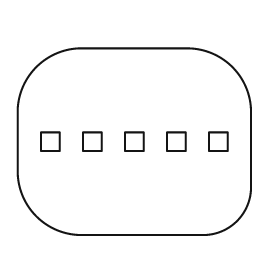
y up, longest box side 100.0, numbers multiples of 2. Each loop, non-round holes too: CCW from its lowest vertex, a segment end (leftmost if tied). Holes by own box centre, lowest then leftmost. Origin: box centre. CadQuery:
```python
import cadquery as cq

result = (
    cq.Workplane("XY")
    .moveTo(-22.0, -40.0)
    .lineTo(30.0, -40.0)
    .threePointArc((44.0, -34.0), (50.0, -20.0))
    .lineTo(50.0, 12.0)
    .threePointArc((42.0, 32.0), (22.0, 40.0))
    .lineTo(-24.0, 40.0)
    .threePointArc((-42.0, 32.0), (-50.0, 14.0))
    .lineTo(-50.0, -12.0)
    .threePointArc((-42.0, -32.0), (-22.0, -40.0))
    .close()
    .moveTo(-40.0, -4.0)
    .lineTo(-32.0, -4.0)
    .lineTo(-32.0, 4.0)
    .lineTo(-40.0, 4.0)
    .close()
    .moveTo(-22.0, -4.0)
    .lineTo(-14.0, -4.0)
    .lineTo(-14.0, 4.0)
    .lineTo(-22.0, 4.0)
    .close()
    .moveTo(-4.0, -4.0)
    .lineTo(4.0, -4.0)
    .lineTo(4.0, 4.0)
    .lineTo(-4.0, 4.0)
    .close()
    .moveTo(14.0, -4.0)
    .lineTo(22.0, -4.0)
    .lineTo(22.0, 4.0)
    .lineTo(14.0, 4.0)
    .close()
    .moveTo(32.0, -4.0)
    .lineTo(40.0, -4.0)
    .lineTo(40.0, 4.0)
    .lineTo(32.0, 4.0)
    .close()
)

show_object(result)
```